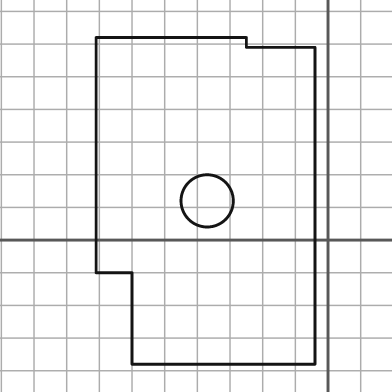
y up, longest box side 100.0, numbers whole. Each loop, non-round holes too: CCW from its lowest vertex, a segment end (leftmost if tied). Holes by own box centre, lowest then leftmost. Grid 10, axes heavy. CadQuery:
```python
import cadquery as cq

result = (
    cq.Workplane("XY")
    .moveTo(-60.0, -38.0)
    .lineTo(-4.0, -38.0)
    .lineTo(-4.0, 59.0)
    .lineTo(-25.0, 59.0)
    .lineTo(-25.0, 62.0)
    .lineTo(-71.0, 62.0)
    .lineTo(-71.0, -10.0)
    .lineTo(-60.0, -10.0)
    .close()
    .moveTo(-37.0, 12.0)
    .circle(8.0)
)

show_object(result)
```